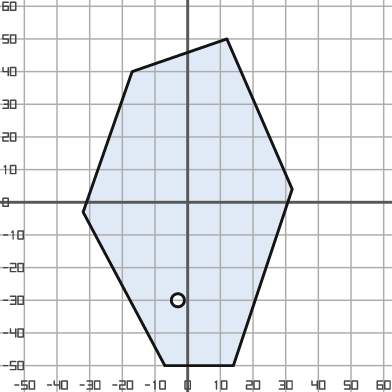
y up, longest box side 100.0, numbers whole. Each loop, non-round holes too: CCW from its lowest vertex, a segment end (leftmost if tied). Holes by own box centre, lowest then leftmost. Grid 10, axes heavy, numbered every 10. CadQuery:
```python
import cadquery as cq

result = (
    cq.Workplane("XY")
    .moveTo(-7.0, -50.0)
    .lineTo(14.0, -50.0)
    .lineTo(32.0, 4.0)
    .lineTo(12.0, 50.0)
    .lineTo(-17.0, 40.0)
    .lineTo(-32.0, -3.0)
    .close()
    .moveTo(-3.0, -30.0)
    .circle(2.0)
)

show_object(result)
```